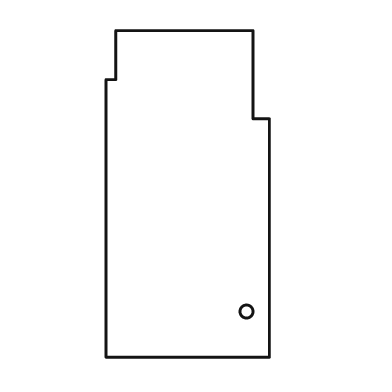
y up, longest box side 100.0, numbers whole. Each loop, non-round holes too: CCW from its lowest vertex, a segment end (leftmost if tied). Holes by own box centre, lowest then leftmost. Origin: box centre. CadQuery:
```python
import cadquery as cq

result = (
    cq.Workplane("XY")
    .moveTo(-25.0, -50.0)
    .lineTo(25.0, -50.0)
    .lineTo(25.0, 23.0)
    .lineTo(20.0, 23.0)
    .lineTo(20.0, 50.0)
    .lineTo(-22.0, 50.0)
    .lineTo(-22.0, 35.0)
    .lineTo(-25.0, 35.0)
    .close()
    .moveTo(18.0, -36.0)
    .circle(2.0)
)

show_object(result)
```